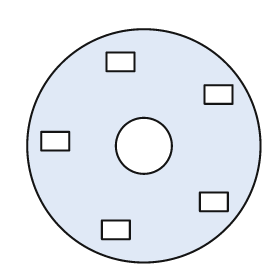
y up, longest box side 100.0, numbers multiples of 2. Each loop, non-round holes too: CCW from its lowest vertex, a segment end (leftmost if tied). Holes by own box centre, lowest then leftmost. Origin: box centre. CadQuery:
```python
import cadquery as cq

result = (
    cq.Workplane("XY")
    .moveTo(0.0, 0.0)
    .circle(50.0)
    .moveTo(-18.0, -40.0)
    .lineTo(-6.0, -40.0)
    .lineTo(-6.0, -32.0)
    .lineTo(-18.0, -32.0)
    .close()
    .moveTo(24.0, -28.0)
    .lineTo(36.0, -28.0)
    .lineTo(36.0, -20.0)
    .lineTo(24.0, -20.0)
    .close()
    .moveTo(0.0, 0.0)
    .circle(12.0)
    .moveTo(-44.0, -2.0)
    .lineTo(-32.0, -2.0)
    .lineTo(-32.0, 6.0)
    .lineTo(-44.0, 6.0)
    .close()
    .moveTo(26.0, 18.0)
    .lineTo(38.0, 18.0)
    .lineTo(38.0, 26.0)
    .lineTo(26.0, 26.0)
    .close()
    .moveTo(-16.0, 32.0)
    .lineTo(-4.0, 32.0)
    .lineTo(-4.0, 40.0)
    .lineTo(-16.0, 40.0)
    .close()
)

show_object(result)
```